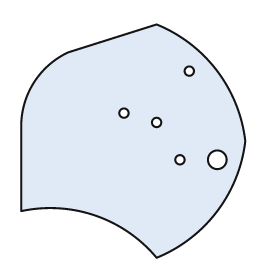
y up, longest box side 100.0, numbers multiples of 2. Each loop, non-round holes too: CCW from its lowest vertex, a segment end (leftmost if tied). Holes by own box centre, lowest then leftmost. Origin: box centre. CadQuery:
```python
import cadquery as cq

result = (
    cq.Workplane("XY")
    .moveTo(10.0, -50.0)
    .threePointArc((36.0, -30.0), (48.0, 0.0))
    .threePointArc((36.0, 30.0), (10.0, 50.0))
    .lineTo(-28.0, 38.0)
    .threePointArc((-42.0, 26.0), (-48.0, 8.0))
    .lineTo(-48.0, -30.0)
    .threePointArc((-16.0, -32.0), (10.0, -50.0))
    .close()
    .moveTo(20.0, -8.0)
    .circle(2.0)
    .moveTo(36.0, -8.0)
    .circle(4.0)
    .moveTo(10.0, 8.0)
    .circle(2.0)
    .moveTo(-4.0, 12.0)
    .circle(2.0)
    .moveTo(24.0, 30.0)
    .circle(2.0)
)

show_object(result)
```